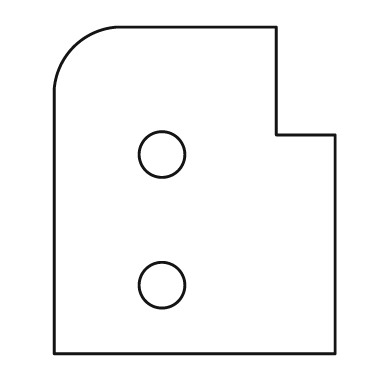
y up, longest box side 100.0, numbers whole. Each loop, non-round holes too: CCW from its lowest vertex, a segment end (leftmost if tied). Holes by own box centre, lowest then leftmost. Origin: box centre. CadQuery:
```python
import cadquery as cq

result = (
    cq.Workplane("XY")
    .moveTo(-43.0, -50.0)
    .lineTo(43.0, -50.0)
    .lineTo(43.0, 17.0)
    .lineTo(25.0, 17.0)
    .lineTo(25.0, 50.0)
    .lineTo(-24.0, 50.0)
    .threePointArc((-37.0, 44.0), (-43.0, 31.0))
    .close()
    .moveTo(-10.0, -29.0)
    .circle(7.0)
    .moveTo(-10.0, 11.0)
    .circle(7.0)
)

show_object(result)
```